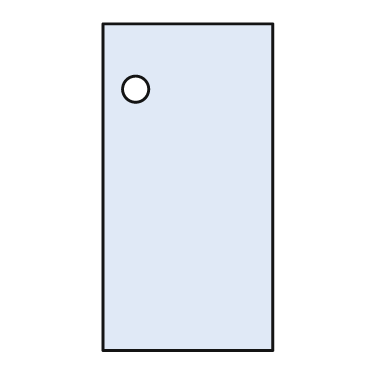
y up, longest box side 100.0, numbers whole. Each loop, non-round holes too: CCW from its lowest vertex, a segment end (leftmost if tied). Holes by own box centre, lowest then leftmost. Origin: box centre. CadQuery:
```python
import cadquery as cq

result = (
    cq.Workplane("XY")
    .moveTo(-26.0, -50.0)
    .lineTo(26.0, -50.0)
    .lineTo(26.0, 50.0)
    .lineTo(-26.0, 50.0)
    .close()
    .moveTo(-16.0, 30.0)
    .circle(4.0)
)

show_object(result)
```